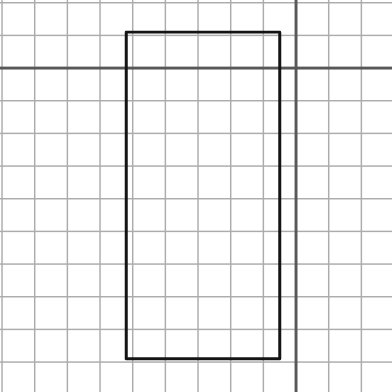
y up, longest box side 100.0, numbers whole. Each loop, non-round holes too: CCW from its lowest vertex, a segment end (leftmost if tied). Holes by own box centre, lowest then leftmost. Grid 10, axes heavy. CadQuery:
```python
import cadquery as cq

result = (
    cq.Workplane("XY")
    .moveTo(-52.0, -89.0)
    .lineTo(-5.0, -89.0)
    .lineTo(-5.0, 11.0)
    .lineTo(-52.0, 11.0)
    .close()
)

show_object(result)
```